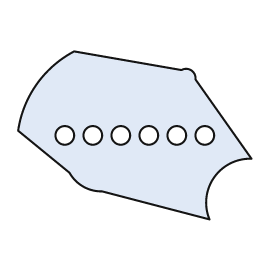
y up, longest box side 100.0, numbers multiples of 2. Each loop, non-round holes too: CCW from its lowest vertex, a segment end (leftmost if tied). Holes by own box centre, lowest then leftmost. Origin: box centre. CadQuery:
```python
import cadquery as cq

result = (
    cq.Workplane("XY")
    .moveTo(32.0, -36.0)
    .threePointArc((34.0, -18.0), (50.0, -10.0))
    .lineTo(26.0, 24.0)
    .threePointArc((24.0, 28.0), (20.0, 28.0))
    .lineTo(-26.0, 36.0)
    .threePointArc((-42.0, 22.0), (-50.0, 2.0))
    .lineTo(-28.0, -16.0)
    .threePointArc((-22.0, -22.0), (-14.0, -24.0))
    .close()
    .moveTo(-30.0, 0.0)
    .circle(4.0)
    .moveTo(-18.0, 0.0)
    .circle(4.0)
    .moveTo(-6.0, 0.0)
    .circle(4.0)
    .moveTo(6.0, 0.0)
    .circle(4.0)
    .moveTo(18.0, 0.0)
    .circle(4.0)
    .moveTo(30.0, 0.0)
    .circle(4.0)
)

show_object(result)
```